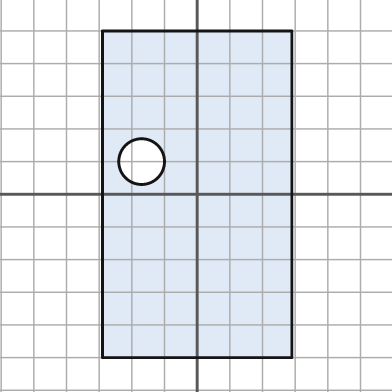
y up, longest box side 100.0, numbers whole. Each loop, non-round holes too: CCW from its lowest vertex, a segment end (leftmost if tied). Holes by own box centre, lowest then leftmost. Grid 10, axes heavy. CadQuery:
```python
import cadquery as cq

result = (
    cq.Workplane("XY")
    .moveTo(-29.0, -50.0)
    .lineTo(29.0, -50.0)
    .lineTo(29.0, 50.0)
    .lineTo(-29.0, 50.0)
    .close()
    .moveTo(-17.0, 10.0)
    .circle(7.0)
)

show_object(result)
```